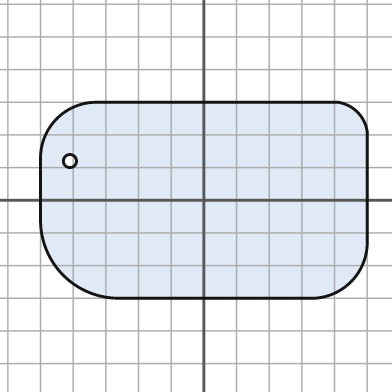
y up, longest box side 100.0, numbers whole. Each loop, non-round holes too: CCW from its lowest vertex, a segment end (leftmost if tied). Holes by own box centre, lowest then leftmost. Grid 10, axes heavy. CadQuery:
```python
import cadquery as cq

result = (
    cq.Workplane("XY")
    .moveTo(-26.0, -30.0)
    .lineTo(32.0, -30.0)
    .threePointArc((45.0, -25.0), (50.0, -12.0))
    .lineTo(50.0, 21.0)
    .threePointArc((47.0, 27.0), (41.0, 30.0))
    .lineTo(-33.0, 30.0)
    .threePointArc((-45.0, 25.0), (-50.0, 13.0))
    .lineTo(-50.0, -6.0)
    .threePointArc((-43.0, -23.0), (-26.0, -30.0))
    .close()
    .moveTo(-41.0, 12.0)
    .circle(2.0)
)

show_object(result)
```